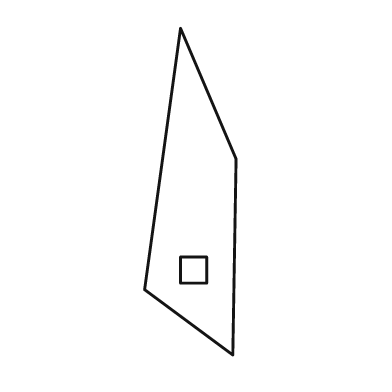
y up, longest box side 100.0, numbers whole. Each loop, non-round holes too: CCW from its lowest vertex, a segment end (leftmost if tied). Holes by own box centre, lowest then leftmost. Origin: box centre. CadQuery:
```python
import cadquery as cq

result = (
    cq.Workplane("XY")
    .moveTo(13.0, -50.0)
    .lineTo(14.0, 10.0)
    .lineTo(-3.0, 50.0)
    .lineTo(-14.0, -30.0)
    .close()
    .moveTo(-3.0, -28.0)
    .lineTo(5.0, -28.0)
    .lineTo(5.0, -20.0)
    .lineTo(-3.0, -20.0)
    .close()
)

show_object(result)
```